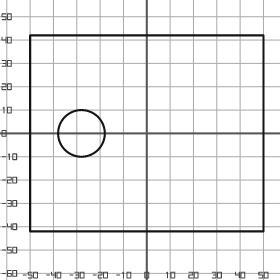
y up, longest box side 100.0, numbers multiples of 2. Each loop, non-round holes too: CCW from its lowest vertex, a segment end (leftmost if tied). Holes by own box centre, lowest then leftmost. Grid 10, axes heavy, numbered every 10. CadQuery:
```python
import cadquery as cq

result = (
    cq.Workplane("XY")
    .moveTo(-50.0, -42.0)
    .lineTo(50.0, -42.0)
    .lineTo(50.0, 42.0)
    .lineTo(-50.0, 42.0)
    .close()
    .moveTo(-28.0, 0.0)
    .circle(10.0)
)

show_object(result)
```